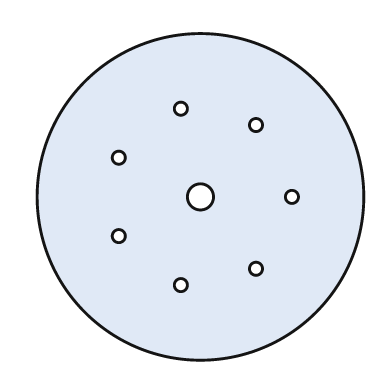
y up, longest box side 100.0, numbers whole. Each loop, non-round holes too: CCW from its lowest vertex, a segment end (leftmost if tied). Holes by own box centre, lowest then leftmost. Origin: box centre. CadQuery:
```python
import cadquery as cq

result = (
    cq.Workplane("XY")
    .moveTo(0.0, 0.0)
    .circle(50.0)
    .moveTo(-6.0, -27.0)
    .circle(2.0)
    .moveTo(17.0, -22.0)
    .circle(2.0)
    .moveTo(-25.0, -12.0)
    .circle(2.0)
    .moveTo(0.0, 0.0)
    .circle(4.0)
    .moveTo(28.0, 0.0)
    .circle(2.0)
    .moveTo(-25.0, 12.0)
    .circle(2.0)
    .moveTo(17.0, 22.0)
    .circle(2.0)
    .moveTo(-6.0, 27.0)
    .circle(2.0)
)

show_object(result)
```